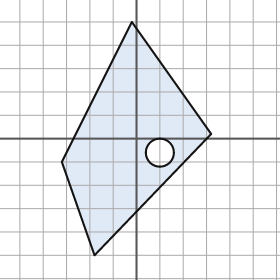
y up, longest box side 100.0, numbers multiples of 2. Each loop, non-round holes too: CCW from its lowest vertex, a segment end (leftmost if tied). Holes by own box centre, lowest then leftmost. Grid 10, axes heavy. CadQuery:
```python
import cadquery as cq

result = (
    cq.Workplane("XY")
    .moveTo(-18.0, -50.0)
    .lineTo(32.0, 2.0)
    .lineTo(-2.0, 50.0)
    .lineTo(-32.0, -10.0)
    .close()
    .moveTo(10.0, -6.0)
    .circle(6.0)
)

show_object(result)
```